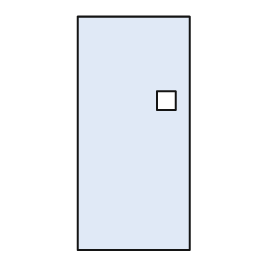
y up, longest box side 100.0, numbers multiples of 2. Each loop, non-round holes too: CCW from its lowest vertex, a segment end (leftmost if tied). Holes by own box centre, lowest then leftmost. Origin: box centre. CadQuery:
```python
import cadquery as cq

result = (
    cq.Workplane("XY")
    .moveTo(-24.0, -50.0)
    .lineTo(24.0, -50.0)
    .lineTo(24.0, 50.0)
    .lineTo(-24.0, 50.0)
    .close()
    .moveTo(10.0, 10.0)
    .lineTo(18.0, 10.0)
    .lineTo(18.0, 18.0)
    .lineTo(10.0, 18.0)
    .close()
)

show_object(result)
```